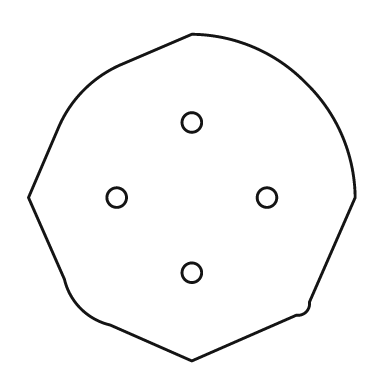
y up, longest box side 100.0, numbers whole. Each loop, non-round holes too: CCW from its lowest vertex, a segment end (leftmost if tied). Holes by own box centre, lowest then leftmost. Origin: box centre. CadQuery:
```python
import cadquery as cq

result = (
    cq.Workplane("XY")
    .moveTo(0.0, -50.0)
    .lineTo(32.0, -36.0)
    .threePointArc((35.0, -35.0), (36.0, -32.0))
    .lineTo(50.0, 0.0)
    .threePointArc((46.0, 19.0), (35.0, 35.0))
    .threePointArc((19.0, 46.0), (0.0, 50.0))
    .lineTo(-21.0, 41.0)
    .threePointArc((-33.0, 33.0), (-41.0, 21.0))
    .lineTo(-50.0, 0.0)
    .lineTo(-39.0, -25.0)
    .threePointArc((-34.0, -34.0), (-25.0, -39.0))
    .close()
    .moveTo(0.0, -23.0)
    .circle(3.0)
    .moveTo(-23.0, 0.0)
    .circle(3.0)
    .moveTo(23.0, 0.0)
    .circle(3.0)
    .moveTo(0.0, 23.0)
    .circle(3.0)
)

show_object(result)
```